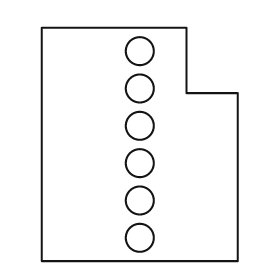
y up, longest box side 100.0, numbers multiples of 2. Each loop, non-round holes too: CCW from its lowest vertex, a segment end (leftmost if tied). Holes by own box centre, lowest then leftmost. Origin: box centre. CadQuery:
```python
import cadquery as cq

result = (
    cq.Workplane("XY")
    .moveTo(-42.0, -50.0)
    .lineTo(42.0, -50.0)
    .lineTo(42.0, 22.0)
    .lineTo(20.0, 22.0)
    .lineTo(20.0, 50.0)
    .lineTo(-42.0, 50.0)
    .close()
    .moveTo(0.0, -40.0)
    .circle(6.0)
    .moveTo(0.0, -24.0)
    .circle(6.0)
    .moveTo(0.0, -8.0)
    .circle(6.0)
    .moveTo(0.0, 8.0)
    .circle(6.0)
    .moveTo(0.0, 24.0)
    .circle(6.0)
    .moveTo(0.0, 40.0)
    .circle(6.0)
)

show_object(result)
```